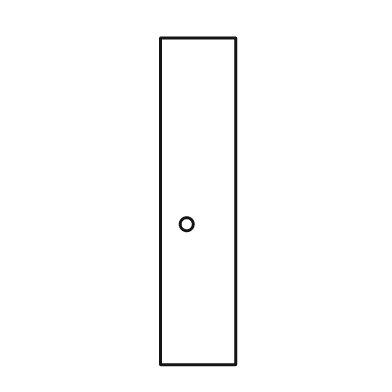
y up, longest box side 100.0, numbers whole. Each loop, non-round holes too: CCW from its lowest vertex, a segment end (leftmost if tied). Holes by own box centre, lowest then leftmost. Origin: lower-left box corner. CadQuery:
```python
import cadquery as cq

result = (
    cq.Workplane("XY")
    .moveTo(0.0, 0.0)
    .lineTo(23.0, 0.0)
    .lineTo(23.0, 100.0)
    .lineTo(0.0, 100.0)
    .close()
    .moveTo(8.0, 43.0)
    .circle(2.0)
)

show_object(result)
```